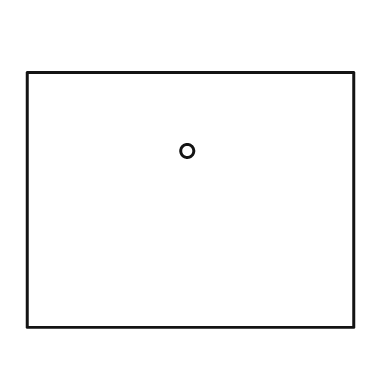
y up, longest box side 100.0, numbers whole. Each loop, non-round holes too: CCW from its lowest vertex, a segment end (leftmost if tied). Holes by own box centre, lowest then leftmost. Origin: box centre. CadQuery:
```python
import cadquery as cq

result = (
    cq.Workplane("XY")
    .moveTo(-50.0, -39.0)
    .lineTo(50.0, -39.0)
    .lineTo(50.0, 39.0)
    .lineTo(-50.0, 39.0)
    .close()
    .moveTo(-1.0, 15.0)
    .circle(2.0)
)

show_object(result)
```